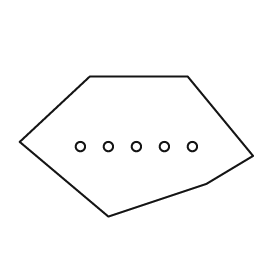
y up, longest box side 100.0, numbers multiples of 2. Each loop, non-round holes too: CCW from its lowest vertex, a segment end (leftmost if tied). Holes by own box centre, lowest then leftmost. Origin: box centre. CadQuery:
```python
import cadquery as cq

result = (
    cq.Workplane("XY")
    .moveTo(-12.0, -30.0)
    .lineTo(30.0, -16.0)
    .lineTo(50.0, -4.0)
    .lineTo(22.0, 30.0)
    .lineTo(-20.0, 30.0)
    .lineTo(-50.0, 2.0)
    .close()
    .moveTo(-24.0, 0.0)
    .circle(2.0)
    .moveTo(-12.0, 0.0)
    .circle(2.0)
    .moveTo(0.0, 0.0)
    .circle(2.0)
    .moveTo(12.0, 0.0)
    .circle(2.0)
    .moveTo(24.0, 0.0)
    .circle(2.0)
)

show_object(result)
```